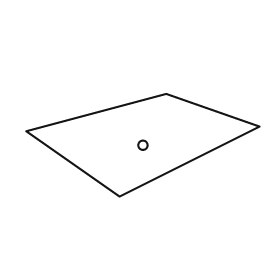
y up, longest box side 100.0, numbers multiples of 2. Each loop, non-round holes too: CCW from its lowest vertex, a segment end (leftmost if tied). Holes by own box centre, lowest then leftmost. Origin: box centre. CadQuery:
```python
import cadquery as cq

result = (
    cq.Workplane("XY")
    .moveTo(-10.0, -22.0)
    .lineTo(50.0, 8.0)
    .lineTo(10.0, 22.0)
    .lineTo(-50.0, 6.0)
    .close()
    .moveTo(0.0, 0.0)
    .circle(2.0)
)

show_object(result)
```